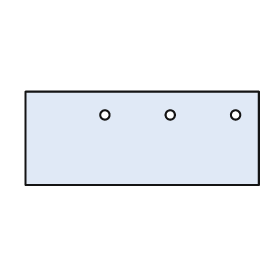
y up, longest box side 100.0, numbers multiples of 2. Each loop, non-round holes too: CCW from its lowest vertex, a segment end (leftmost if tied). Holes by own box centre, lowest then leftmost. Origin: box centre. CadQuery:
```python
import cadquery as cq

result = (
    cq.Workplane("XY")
    .moveTo(-50.0, -20.0)
    .lineTo(50.0, -20.0)
    .lineTo(50.0, 20.0)
    .lineTo(-50.0, 20.0)
    .close()
    .moveTo(-16.0, 10.0)
    .circle(2.0)
    .moveTo(12.0, 10.0)
    .circle(2.0)
    .moveTo(40.0, 10.0)
    .circle(2.0)
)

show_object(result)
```